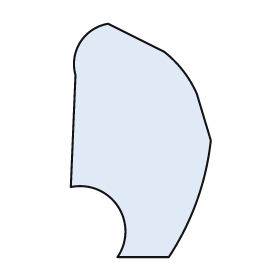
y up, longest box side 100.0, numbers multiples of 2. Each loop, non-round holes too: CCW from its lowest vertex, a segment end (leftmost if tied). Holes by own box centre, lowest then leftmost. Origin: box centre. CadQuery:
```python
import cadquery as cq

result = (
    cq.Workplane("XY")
    .moveTo(-10.0, -50.0)
    .lineTo(12.0, -50.0)
    .threePointArc((24.0, -26.0), (30.0, 0.0))
    .lineTo(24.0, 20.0)
    .threePointArc((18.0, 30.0), (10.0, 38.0))
    .lineTo(-14.0, 50.0)
    .threePointArc((-26.0, 42.0), (-28.0, 28.0))
    .lineTo(-30.0, -20.0)
    .threePointArc((-10.0, -28.0), (-10.0, -50.0))
    .close()
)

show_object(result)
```